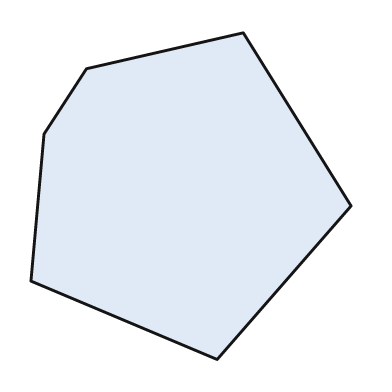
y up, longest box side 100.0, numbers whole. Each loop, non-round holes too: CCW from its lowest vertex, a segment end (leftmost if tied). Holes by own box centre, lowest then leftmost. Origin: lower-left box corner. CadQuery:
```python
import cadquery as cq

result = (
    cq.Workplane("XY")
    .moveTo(57.0, 0.0)
    .lineTo(98.0, 47.0)
    .lineTo(65.0, 100.0)
    .lineTo(17.0, 89.0)
    .lineTo(4.0, 69.0)
    .lineTo(0.0, 24.0)
    .close()
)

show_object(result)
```